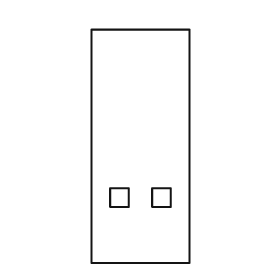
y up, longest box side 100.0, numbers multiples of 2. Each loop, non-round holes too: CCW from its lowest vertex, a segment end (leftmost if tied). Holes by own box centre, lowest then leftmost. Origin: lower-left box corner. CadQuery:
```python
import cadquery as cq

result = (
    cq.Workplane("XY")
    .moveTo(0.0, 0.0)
    .lineTo(42.0, 0.0)
    .lineTo(42.0, 100.0)
    .lineTo(0.0, 100.0)
    .close()
    .moveTo(8.0, 24.0)
    .lineTo(16.0, 24.0)
    .lineTo(16.0, 32.0)
    .lineTo(8.0, 32.0)
    .close()
    .moveTo(26.0, 24.0)
    .lineTo(34.0, 24.0)
    .lineTo(34.0, 32.0)
    .lineTo(26.0, 32.0)
    .close()
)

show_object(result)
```